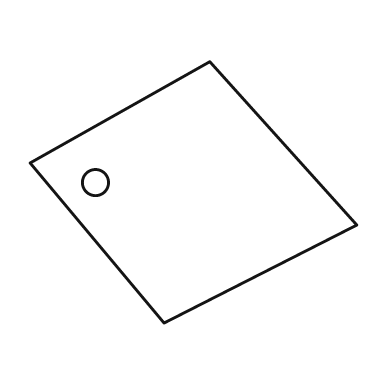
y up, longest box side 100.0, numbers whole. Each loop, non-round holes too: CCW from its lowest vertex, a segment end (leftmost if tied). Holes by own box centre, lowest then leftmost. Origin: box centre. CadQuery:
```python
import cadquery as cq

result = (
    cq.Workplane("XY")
    .moveTo(-9.0, -40.0)
    .lineTo(50.0, -10.0)
    .lineTo(5.0, 40.0)
    .lineTo(-50.0, 9.0)
    .close()
    .moveTo(-30.0, 3.0)
    .circle(4.0)
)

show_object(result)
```